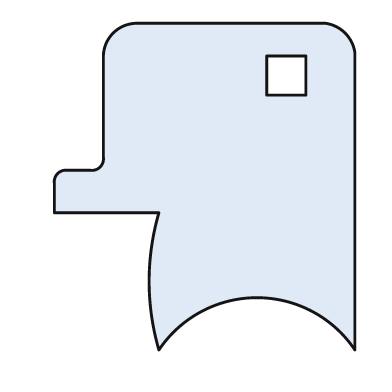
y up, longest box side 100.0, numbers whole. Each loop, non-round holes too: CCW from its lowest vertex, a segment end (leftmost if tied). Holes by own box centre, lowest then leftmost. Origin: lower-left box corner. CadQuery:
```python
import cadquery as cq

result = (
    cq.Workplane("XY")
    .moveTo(32.0, 0.0)
    .threePointArc((62.0, 16.0), (92.0, 0.0))
    .lineTo(92.0, 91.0)
    .threePointArc((89.0, 97.0), (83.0, 100.0))
    .lineTo(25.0, 100.0)
    .threePointArc((18.0, 97.0), (15.0, 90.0))
    .lineTo(15.0, 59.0)
    .threePointArc((14.0, 56.0), (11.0, 55.0))
    .lineTo(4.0, 55.0)
    .threePointArc((1.0, 54.0), (0.0, 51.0))
    .lineTo(0.0, 42.0)
    .lineTo(32.0, 42.0)
    .threePointArc((29.0, 21.0), (32.0, 0.0))
    .close()
    .moveTo(65.0, 78.0)
    .lineTo(77.0, 78.0)
    .lineTo(77.0, 90.0)
    .lineTo(65.0, 90.0)
    .close()
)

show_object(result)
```